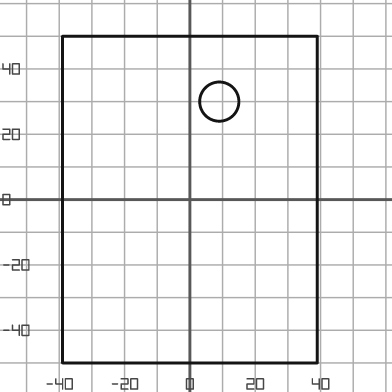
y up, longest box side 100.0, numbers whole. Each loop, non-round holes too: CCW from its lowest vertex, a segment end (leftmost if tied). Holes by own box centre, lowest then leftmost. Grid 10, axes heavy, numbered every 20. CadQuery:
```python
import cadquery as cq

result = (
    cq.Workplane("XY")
    .moveTo(-39.0, -50.0)
    .lineTo(39.0, -50.0)
    .lineTo(39.0, 50.0)
    .lineTo(-39.0, 50.0)
    .close()
    .moveTo(9.0, 30.0)
    .circle(6.0)
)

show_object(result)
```